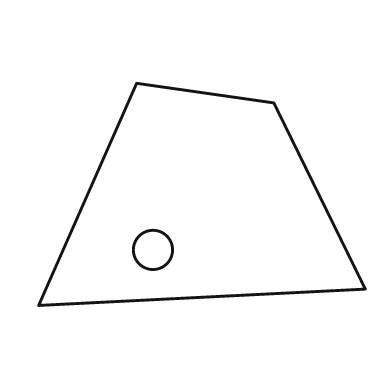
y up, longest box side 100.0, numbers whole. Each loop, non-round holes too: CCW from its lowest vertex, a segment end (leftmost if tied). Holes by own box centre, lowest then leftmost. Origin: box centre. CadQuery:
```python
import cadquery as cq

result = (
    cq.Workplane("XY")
    .moveTo(-50.0, -34.0)
    .lineTo(50.0, -29.0)
    .lineTo(22.0, 28.0)
    .lineTo(-20.0, 34.0)
    .close()
    .moveTo(-15.0, -17.0)
    .circle(6.0)
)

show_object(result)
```